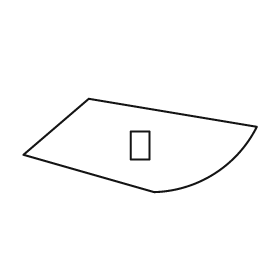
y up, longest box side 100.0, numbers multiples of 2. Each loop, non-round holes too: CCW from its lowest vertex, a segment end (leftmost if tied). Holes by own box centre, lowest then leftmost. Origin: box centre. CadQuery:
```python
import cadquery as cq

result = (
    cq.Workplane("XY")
    .moveTo(6.0, -20.0)
    .threePointArc((32.0, -12.0), (50.0, 8.0))
    .lineTo(-22.0, 20.0)
    .lineTo(-50.0, -4.0)
    .close()
    .moveTo(-4.0, -6.0)
    .lineTo(4.0, -6.0)
    .lineTo(4.0, 6.0)
    .lineTo(-4.0, 6.0)
    .close()
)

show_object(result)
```